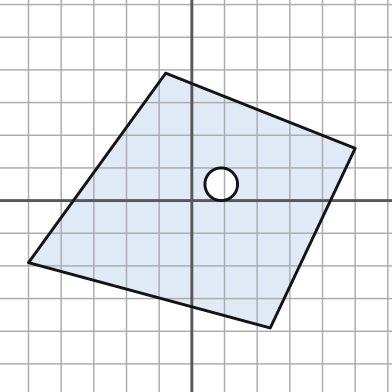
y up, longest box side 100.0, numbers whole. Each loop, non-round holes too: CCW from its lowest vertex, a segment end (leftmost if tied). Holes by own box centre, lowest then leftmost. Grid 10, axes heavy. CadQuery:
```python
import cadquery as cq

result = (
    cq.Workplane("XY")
    .moveTo(24.0, -39.0)
    .lineTo(50.0, 16.0)
    .lineTo(-8.0, 39.0)
    .lineTo(-50.0, -19.0)
    .close()
    .moveTo(9.0, 5.0)
    .circle(5.0)
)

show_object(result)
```